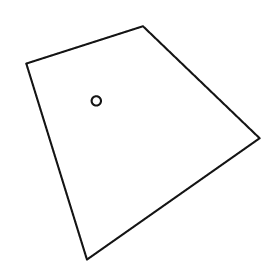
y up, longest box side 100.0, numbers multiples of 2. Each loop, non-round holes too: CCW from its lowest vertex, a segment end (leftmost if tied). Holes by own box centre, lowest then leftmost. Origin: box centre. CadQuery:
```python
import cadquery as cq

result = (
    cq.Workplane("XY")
    .moveTo(-24.0, -50.0)
    .lineTo(50.0, 2.0)
    .lineTo(0.0, 50.0)
    .lineTo(-50.0, 34.0)
    .close()
    .moveTo(-20.0, 18.0)
    .circle(2.0)
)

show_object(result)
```